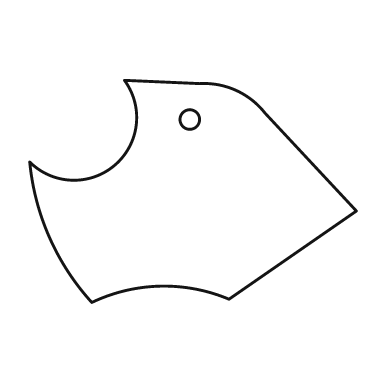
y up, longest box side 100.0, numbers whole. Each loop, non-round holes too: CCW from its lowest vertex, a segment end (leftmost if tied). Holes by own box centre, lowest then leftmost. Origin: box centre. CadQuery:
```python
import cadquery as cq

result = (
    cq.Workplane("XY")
    .moveTo(-31.0, -34.0)
    .threePointArc((-10.0, -29.0), (11.0, -33.0))
    .lineTo(50.0, -6.0)
    .lineTo(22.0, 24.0)
    .threePointArc((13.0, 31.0), (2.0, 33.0))
    .lineTo(-21.0, 34.0)
    .threePointArc((-24.0, 8.0), (-50.0, 9.0))
    .threePointArc((-44.0, -14.0), (-31.0, -34.0))
    .close()
    .moveTo(-1.0, 22.0)
    .circle(3.0)
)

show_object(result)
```